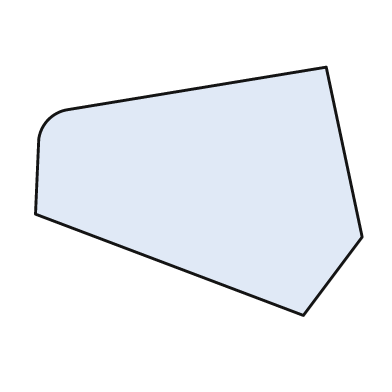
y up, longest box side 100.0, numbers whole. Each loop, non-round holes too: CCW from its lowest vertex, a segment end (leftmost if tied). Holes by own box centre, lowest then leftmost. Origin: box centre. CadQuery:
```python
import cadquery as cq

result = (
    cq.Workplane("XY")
    .moveTo(32.0, -38.0)
    .lineTo(50.0, -14.0)
    .lineTo(39.0, 38.0)
    .lineTo(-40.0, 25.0)
    .threePointArc((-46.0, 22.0), (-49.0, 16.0))
    .lineTo(-50.0, -7.0)
    .close()
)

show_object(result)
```